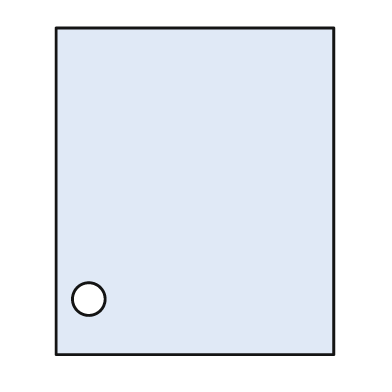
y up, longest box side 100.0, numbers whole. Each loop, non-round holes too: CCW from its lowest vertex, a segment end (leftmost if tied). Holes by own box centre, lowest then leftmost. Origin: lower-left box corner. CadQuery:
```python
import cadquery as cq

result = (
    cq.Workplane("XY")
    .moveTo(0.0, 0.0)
    .lineTo(85.0, 0.0)
    .lineTo(85.0, 100.0)
    .lineTo(0.0, 100.0)
    .close()
    .moveTo(10.0, 17.0)
    .circle(5.0)
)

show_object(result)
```